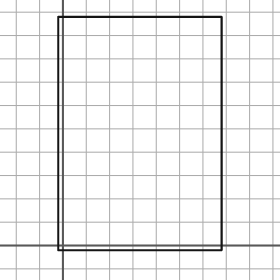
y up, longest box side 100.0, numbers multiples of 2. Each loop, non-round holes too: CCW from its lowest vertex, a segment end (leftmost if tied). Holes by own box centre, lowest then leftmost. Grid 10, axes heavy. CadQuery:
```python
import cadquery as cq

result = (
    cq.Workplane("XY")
    .moveTo(-2.0, -2.0)
    .lineTo(68.0, -2.0)
    .lineTo(68.0, 98.0)
    .lineTo(-2.0, 98.0)
    .close()
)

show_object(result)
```